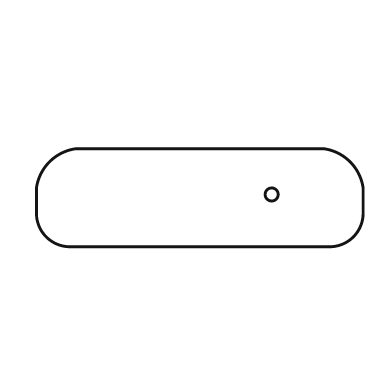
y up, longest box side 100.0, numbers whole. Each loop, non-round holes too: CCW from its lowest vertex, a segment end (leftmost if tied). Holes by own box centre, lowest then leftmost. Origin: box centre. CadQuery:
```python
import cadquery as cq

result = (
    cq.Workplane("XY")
    .moveTo(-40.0, -15.0)
    .lineTo(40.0, -15.0)
    .threePointArc((47.0, -12.0), (50.0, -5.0))
    .lineTo(50.0, 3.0)
    .threePointArc((46.0, 11.0), (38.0, 15.0))
    .lineTo(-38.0, 15.0)
    .threePointArc((-46.0, 11.0), (-50.0, 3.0))
    .lineTo(-50.0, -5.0)
    .threePointArc((-47.0, -12.0), (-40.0, -15.0))
    .close()
    .moveTo(22.0, 1.0)
    .circle(2.0)
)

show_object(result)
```